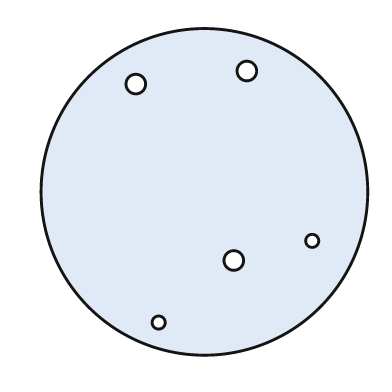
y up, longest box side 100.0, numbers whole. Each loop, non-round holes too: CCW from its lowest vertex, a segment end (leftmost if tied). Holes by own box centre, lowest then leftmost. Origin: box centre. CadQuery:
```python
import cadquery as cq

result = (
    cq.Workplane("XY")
    .moveTo(0.0, 0.0)
    .circle(50.0)
    .moveTo(-14.0, -40.0)
    .circle(2.0)
    .moveTo(9.0, -21.0)
    .circle(3.0)
    .moveTo(33.0, -15.0)
    .circle(2.0)
    .moveTo(-21.0, 33.0)
    .circle(3.0)
    .moveTo(13.0, 37.0)
    .circle(3.0)
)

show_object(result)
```